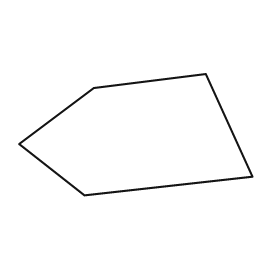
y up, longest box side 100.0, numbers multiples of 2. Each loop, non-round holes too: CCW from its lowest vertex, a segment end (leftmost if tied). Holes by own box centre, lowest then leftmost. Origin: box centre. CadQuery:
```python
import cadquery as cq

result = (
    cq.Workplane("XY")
    .moveTo(-22.0, -26.0)
    .lineTo(50.0, -18.0)
    .lineTo(30.0, 26.0)
    .lineTo(-18.0, 20.0)
    .lineTo(-50.0, -4.0)
    .close()
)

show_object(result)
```